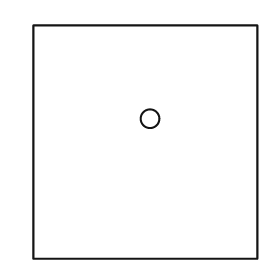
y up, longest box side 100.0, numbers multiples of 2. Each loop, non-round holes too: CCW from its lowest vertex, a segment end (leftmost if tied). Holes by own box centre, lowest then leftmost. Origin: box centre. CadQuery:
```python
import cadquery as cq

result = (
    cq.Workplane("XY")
    .moveTo(-48.0, -50.0)
    .lineTo(48.0, -50.0)
    .lineTo(48.0, 50.0)
    .lineTo(-48.0, 50.0)
    .close()
    .moveTo(2.0, 10.0)
    .circle(4.0)
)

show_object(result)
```